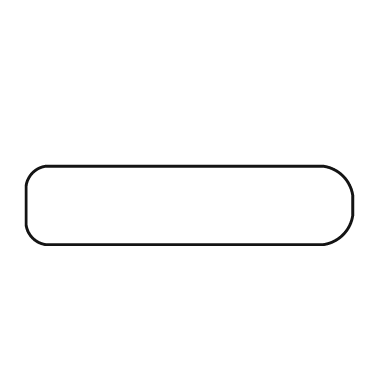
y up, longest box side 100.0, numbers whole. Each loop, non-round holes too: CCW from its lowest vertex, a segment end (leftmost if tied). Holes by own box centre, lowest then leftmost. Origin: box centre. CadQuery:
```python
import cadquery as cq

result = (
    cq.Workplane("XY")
    .moveTo(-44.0, -12.0)
    .lineTo(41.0, -12.0)
    .threePointArc((47.0, -9.0), (50.0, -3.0))
    .lineTo(50.0, 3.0)
    .threePointArc((47.0, 9.0), (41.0, 12.0))
    .lineTo(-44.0, 12.0)
    .threePointArc((-48.0, 10.0), (-50.0, 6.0))
    .lineTo(-50.0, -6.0)
    .threePointArc((-48.0, -10.0), (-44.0, -12.0))
    .close()
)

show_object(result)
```